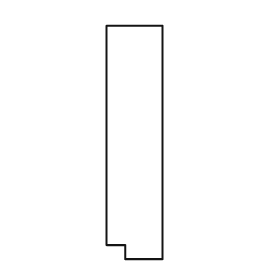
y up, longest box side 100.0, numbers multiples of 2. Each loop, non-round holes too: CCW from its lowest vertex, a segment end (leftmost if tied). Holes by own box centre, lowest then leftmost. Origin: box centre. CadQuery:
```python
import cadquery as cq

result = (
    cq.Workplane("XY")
    .moveTo(-4.0, -50.0)
    .lineTo(12.0, -50.0)
    .lineTo(12.0, 50.0)
    .lineTo(-12.0, 50.0)
    .lineTo(-12.0, -44.0)
    .lineTo(-4.0, -44.0)
    .close()
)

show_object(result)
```